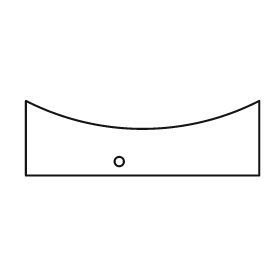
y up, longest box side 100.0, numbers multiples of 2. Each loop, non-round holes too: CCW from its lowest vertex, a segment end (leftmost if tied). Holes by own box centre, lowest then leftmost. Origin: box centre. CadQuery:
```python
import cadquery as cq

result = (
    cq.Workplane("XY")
    .moveTo(-50.0, -16.0)
    .lineTo(50.0, -16.0)
    .lineTo(50.0, 16.0)
    .threePointArc((0.0, 4.0), (-50.0, 16.0))
    .close()
    .moveTo(-10.0, -10.0)
    .circle(2.0)
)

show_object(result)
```